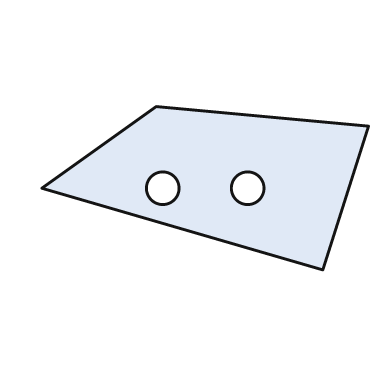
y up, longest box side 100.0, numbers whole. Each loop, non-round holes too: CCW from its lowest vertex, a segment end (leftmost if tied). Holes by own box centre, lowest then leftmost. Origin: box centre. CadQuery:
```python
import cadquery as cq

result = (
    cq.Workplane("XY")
    .moveTo(36.0, -25.0)
    .lineTo(50.0, 19.0)
    .lineTo(-15.0, 25.0)
    .lineTo(-50.0, 0.0)
    .close()
    .moveTo(-13.0, 0.0)
    .circle(5.0)
    .moveTo(13.0, 0.0)
    .circle(5.0)
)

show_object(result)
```